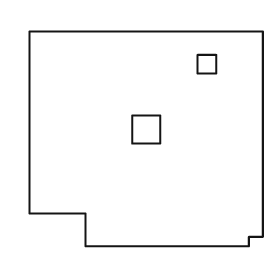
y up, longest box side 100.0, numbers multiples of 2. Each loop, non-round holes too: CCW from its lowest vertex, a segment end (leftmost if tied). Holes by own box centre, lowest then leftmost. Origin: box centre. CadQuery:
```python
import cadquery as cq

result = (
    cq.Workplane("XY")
    .moveTo(-26.0, -46.0)
    .lineTo(44.0, -46.0)
    .lineTo(44.0, -42.0)
    .lineTo(50.0, -42.0)
    .lineTo(50.0, 46.0)
    .lineTo(-50.0, 46.0)
    .lineTo(-50.0, -32.0)
    .lineTo(-26.0, -32.0)
    .close()
    .moveTo(-6.0, -2.0)
    .lineTo(6.0, -2.0)
    .lineTo(6.0, 10.0)
    .lineTo(-6.0, 10.0)
    .close()
    .moveTo(22.0, 28.0)
    .lineTo(30.0, 28.0)
    .lineTo(30.0, 36.0)
    .lineTo(22.0, 36.0)
    .close()
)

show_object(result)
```